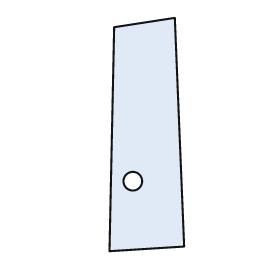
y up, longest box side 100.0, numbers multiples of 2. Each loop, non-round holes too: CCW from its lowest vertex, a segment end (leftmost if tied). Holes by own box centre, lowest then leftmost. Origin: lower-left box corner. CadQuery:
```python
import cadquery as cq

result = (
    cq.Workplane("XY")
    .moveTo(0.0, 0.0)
    .lineTo(32.0, 2.0)
    .lineTo(28.0, 100.0)
    .lineTo(2.0, 96.0)
    .close()
    .moveTo(10.0, 30.0)
    .circle(4.0)
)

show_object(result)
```